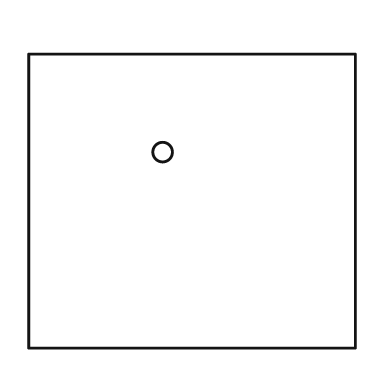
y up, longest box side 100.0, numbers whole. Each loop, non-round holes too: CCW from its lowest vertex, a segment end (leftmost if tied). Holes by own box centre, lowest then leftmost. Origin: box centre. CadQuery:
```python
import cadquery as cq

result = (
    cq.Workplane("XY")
    .moveTo(-50.0, -45.0)
    .lineTo(50.0, -45.0)
    .lineTo(50.0, 45.0)
    .lineTo(-50.0, 45.0)
    .close()
    .moveTo(-9.0, 15.0)
    .circle(3.0)
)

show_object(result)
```